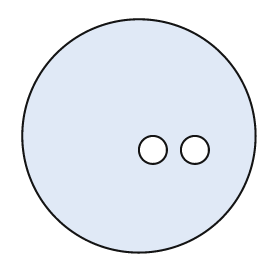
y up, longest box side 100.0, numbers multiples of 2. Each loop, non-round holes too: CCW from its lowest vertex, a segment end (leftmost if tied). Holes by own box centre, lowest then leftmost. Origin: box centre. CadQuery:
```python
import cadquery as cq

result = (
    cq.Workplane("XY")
    .moveTo(0.0, 0.0)
    .circle(50.0)
    .moveTo(6.0, -6.0)
    .circle(6.0)
    .moveTo(24.0, -6.0)
    .circle(6.0)
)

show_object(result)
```